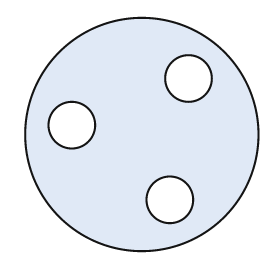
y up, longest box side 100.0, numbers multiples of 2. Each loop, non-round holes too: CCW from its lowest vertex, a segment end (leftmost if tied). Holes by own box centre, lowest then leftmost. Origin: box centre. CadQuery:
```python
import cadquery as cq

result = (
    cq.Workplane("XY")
    .moveTo(0.0, 0.0)
    .circle(50.0)
    .moveTo(12.0, -28.0)
    .circle(10.0)
    .moveTo(-30.0, 4.0)
    .circle(10.0)
    .moveTo(20.0, 24.0)
    .circle(10.0)
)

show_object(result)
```